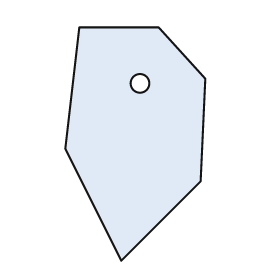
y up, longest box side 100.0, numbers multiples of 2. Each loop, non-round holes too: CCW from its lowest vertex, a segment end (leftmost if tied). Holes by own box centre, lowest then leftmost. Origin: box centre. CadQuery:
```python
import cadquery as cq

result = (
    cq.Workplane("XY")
    .moveTo(-6.0, -50.0)
    .lineTo(28.0, -16.0)
    .lineTo(30.0, 28.0)
    .lineTo(10.0, 50.0)
    .lineTo(-24.0, 50.0)
    .lineTo(-30.0, -2.0)
    .close()
    .moveTo(2.0, 26.0)
    .circle(4.0)
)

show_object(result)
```